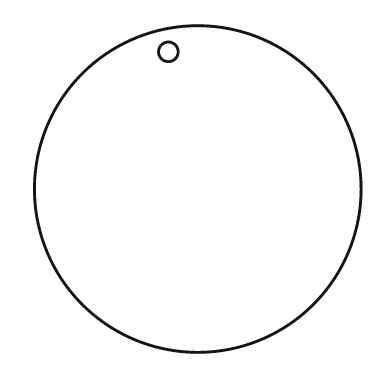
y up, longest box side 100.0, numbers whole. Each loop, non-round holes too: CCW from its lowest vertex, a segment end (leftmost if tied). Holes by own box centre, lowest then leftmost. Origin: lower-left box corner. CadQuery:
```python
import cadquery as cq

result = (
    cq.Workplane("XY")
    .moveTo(50.0, 50.0)
    .circle(50.0)
    .moveTo(41.0, 92.0)
    .circle(3.0)
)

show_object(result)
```